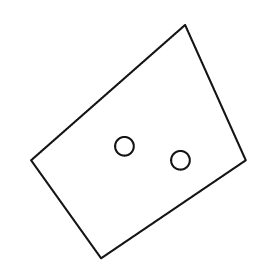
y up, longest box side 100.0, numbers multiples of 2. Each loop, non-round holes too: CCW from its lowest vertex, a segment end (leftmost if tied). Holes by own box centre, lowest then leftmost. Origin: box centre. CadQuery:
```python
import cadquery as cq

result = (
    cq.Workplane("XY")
    .moveTo(-16.0, -50.0)
    .lineTo(46.0, -8.0)
    .lineTo(20.0, 50.0)
    .lineTo(-46.0, -8.0)
    .close()
    .moveTo(18.0, -8.0)
    .circle(4.0)
    .moveTo(-6.0, -2.0)
    .circle(4.0)
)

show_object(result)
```